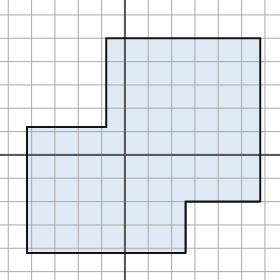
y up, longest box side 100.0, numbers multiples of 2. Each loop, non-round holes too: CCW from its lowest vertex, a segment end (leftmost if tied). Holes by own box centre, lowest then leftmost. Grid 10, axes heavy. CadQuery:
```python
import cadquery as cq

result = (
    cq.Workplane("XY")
    .moveTo(-42.0, -42.0)
    .lineTo(26.0, -42.0)
    .lineTo(26.0, -20.0)
    .lineTo(58.0, -20.0)
    .lineTo(58.0, 50.0)
    .lineTo(-8.0, 50.0)
    .lineTo(-8.0, 12.0)
    .lineTo(-42.0, 12.0)
    .close()
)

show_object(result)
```